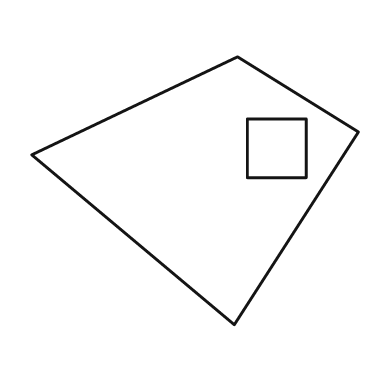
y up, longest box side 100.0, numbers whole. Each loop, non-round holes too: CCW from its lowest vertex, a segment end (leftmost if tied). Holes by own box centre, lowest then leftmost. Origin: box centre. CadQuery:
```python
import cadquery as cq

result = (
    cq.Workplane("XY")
    .moveTo(12.0, -41.0)
    .lineTo(50.0, 18.0)
    .lineTo(13.0, 41.0)
    .lineTo(-50.0, 11.0)
    .close()
    .moveTo(16.0, 4.0)
    .lineTo(34.0, 4.0)
    .lineTo(34.0, 22.0)
    .lineTo(16.0, 22.0)
    .close()
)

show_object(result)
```